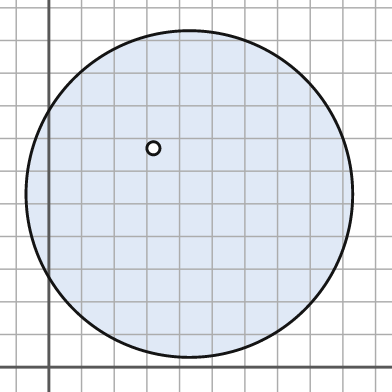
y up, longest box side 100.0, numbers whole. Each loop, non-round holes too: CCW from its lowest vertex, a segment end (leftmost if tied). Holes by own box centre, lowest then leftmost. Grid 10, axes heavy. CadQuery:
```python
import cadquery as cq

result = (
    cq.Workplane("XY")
    .moveTo(43.0, 53.0)
    .circle(50.0)
    .moveTo(32.0, 67.0)
    .circle(2.0)
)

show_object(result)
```